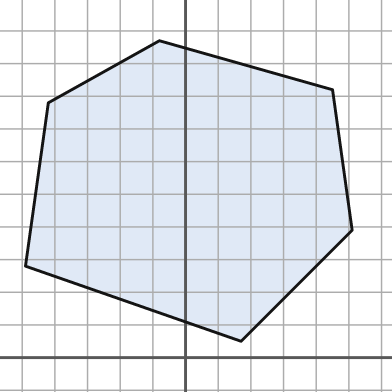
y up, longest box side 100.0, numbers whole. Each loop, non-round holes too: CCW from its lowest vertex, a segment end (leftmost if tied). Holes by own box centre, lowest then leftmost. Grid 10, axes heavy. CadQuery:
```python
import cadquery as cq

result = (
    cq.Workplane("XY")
    .moveTo(17.0, 5.0)
    .lineTo(51.0, 39.0)
    .lineTo(45.0, 82.0)
    .lineTo(-8.0, 97.0)
    .lineTo(-42.0, 78.0)
    .lineTo(-49.0, 28.0)
    .close()
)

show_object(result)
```